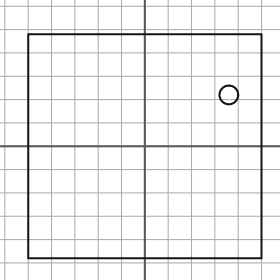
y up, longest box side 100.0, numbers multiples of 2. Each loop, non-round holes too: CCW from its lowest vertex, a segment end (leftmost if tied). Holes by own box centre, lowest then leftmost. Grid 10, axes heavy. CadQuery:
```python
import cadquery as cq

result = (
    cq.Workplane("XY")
    .moveTo(-50.0, -48.0)
    .lineTo(50.0, -48.0)
    .lineTo(50.0, 48.0)
    .lineTo(-50.0, 48.0)
    .close()
    .moveTo(36.0, 22.0)
    .circle(4.0)
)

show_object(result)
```